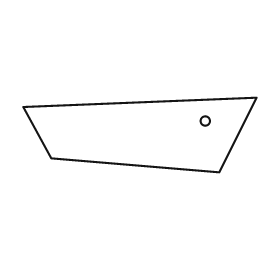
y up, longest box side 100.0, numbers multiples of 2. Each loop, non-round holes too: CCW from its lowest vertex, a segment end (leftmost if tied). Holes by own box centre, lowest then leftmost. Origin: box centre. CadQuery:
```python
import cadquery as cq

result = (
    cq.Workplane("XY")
    .moveTo(34.0, -16.0)
    .lineTo(50.0, 16.0)
    .lineTo(-50.0, 12.0)
    .lineTo(-38.0, -10.0)
    .close()
    .moveTo(28.0, 6.0)
    .circle(2.0)
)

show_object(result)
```